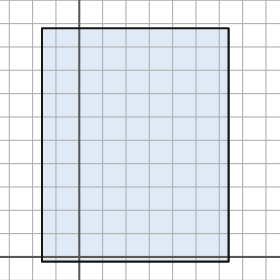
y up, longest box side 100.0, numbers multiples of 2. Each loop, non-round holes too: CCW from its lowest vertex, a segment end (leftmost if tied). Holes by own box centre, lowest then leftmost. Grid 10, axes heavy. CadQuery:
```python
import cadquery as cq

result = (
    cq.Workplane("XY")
    .moveTo(-16.0, -2.0)
    .lineTo(64.0, -2.0)
    .lineTo(64.0, 98.0)
    .lineTo(-16.0, 98.0)
    .close()
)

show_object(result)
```